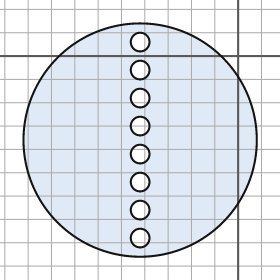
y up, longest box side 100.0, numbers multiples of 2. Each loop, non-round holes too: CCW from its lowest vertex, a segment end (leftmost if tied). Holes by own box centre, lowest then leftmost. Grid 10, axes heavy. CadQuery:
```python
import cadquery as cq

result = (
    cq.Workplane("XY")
    .moveTo(-42.0, -36.0)
    .circle(50.0)
    .moveTo(-42.0, -78.0)
    .circle(4.0)
    .moveTo(-42.0, -66.0)
    .circle(4.0)
    .moveTo(-42.0, -54.0)
    .circle(4.0)
    .moveTo(-42.0, -42.0)
    .circle(4.0)
    .moveTo(-42.0, -30.0)
    .circle(4.0)
    .moveTo(-42.0, -18.0)
    .circle(4.0)
    .moveTo(-42.0, -6.0)
    .circle(4.0)
    .moveTo(-42.0, 6.0)
    .circle(4.0)
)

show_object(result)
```